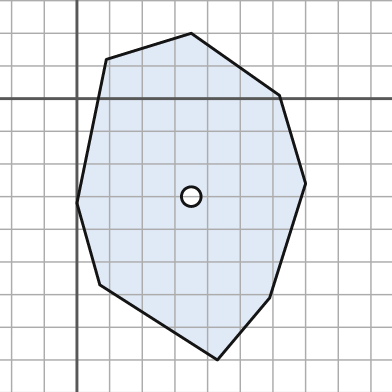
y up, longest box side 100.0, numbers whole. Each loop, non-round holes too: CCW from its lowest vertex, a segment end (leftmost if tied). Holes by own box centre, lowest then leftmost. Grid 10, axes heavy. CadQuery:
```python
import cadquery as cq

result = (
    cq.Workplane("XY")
    .moveTo(43.0, -80.0)
    .lineTo(59.0, -61.0)
    .lineTo(70.0, -26.0)
    .lineTo(62.0, 1.0)
    .lineTo(35.0, 20.0)
    .lineTo(9.0, 12.0)
    .lineTo(0.0, -32.0)
    .lineTo(7.0, -57.0)
    .close()
    .moveTo(35.0, -30.0)
    .circle(3.0)
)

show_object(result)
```